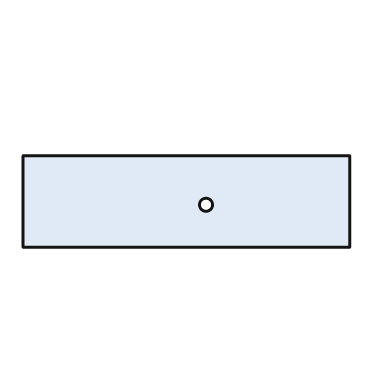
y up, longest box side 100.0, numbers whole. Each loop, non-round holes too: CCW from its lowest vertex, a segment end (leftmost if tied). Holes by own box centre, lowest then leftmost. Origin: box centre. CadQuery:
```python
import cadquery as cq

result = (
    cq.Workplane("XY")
    .moveTo(-50.0, -14.0)
    .lineTo(50.0, -14.0)
    .lineTo(50.0, 14.0)
    .lineTo(-50.0, 14.0)
    .close()
    .moveTo(6.0, -1.0)
    .circle(2.0)
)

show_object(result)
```